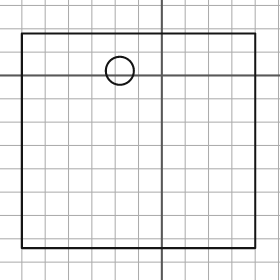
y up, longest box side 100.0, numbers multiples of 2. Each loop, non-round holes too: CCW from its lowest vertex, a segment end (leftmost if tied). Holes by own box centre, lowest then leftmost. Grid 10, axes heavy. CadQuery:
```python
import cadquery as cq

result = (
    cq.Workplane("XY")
    .moveTo(-60.0, -74.0)
    .lineTo(40.0, -74.0)
    .lineTo(40.0, 18.0)
    .lineTo(-60.0, 18.0)
    .close()
    .moveTo(-18.0, 2.0)
    .circle(6.0)
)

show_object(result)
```